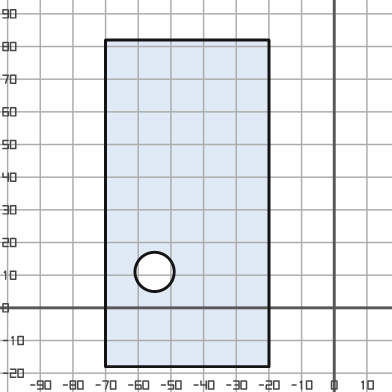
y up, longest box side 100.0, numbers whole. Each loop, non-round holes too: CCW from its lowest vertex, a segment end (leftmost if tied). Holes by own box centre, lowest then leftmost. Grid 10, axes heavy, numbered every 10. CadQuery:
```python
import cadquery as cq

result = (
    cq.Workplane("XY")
    .moveTo(-70.0, -18.0)
    .lineTo(-20.0, -18.0)
    .lineTo(-20.0, 82.0)
    .lineTo(-70.0, 82.0)
    .close()
    .moveTo(-55.0, 11.0)
    .circle(6.0)
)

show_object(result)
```